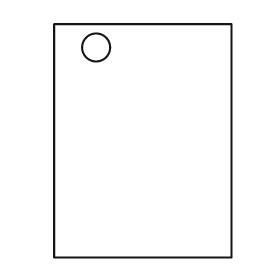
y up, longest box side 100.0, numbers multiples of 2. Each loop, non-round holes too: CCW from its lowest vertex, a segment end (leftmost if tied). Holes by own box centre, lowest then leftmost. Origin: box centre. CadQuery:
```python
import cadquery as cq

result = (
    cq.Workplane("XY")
    .moveTo(-38.0, -50.0)
    .lineTo(38.0, -50.0)
    .lineTo(38.0, 50.0)
    .lineTo(-38.0, 50.0)
    .close()
    .moveTo(-20.0, 40.0)
    .circle(6.0)
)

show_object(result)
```